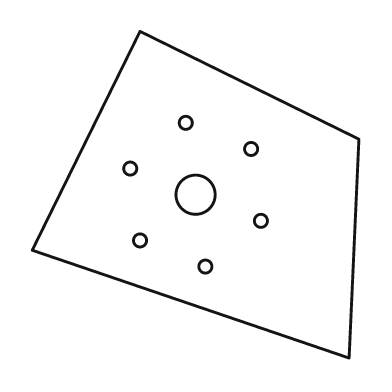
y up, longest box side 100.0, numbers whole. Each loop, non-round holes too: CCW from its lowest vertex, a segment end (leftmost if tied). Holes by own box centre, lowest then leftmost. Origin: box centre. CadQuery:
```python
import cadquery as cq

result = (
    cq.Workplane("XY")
    .moveTo(47.0, -50.0)
    .lineTo(50.0, 17.0)
    .lineTo(-17.0, 50.0)
    .lineTo(-50.0, -17.0)
    .close()
    .moveTo(3.0, -22.0)
    .circle(2.0)
    .moveTo(-17.0, -14.0)
    .circle(2.0)
    .moveTo(20.0, -8.0)
    .circle(2.0)
    .moveTo(0.0, 0.0)
    .circle(6.0)
    .moveTo(-20.0, 8.0)
    .circle(2.0)
    .moveTo(17.0, 14.0)
    .circle(2.0)
    .moveTo(-3.0, 22.0)
    .circle(2.0)
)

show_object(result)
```